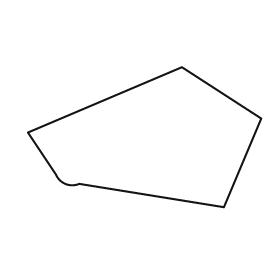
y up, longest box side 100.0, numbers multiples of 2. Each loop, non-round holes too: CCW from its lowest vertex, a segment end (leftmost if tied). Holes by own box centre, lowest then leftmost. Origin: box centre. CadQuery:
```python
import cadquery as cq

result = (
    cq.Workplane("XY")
    .moveTo(34.0, -30.0)
    .lineTo(50.0, 8.0)
    .lineTo(16.0, 30.0)
    .lineTo(-50.0, 2.0)
    .lineTo(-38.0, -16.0)
    .threePointArc((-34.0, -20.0), (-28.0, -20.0))
    .close()
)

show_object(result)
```